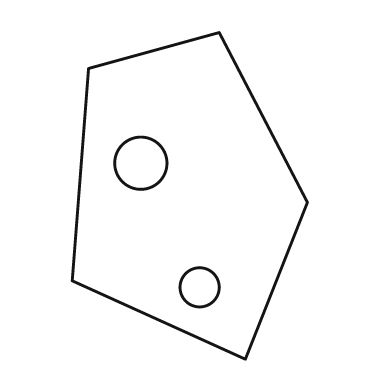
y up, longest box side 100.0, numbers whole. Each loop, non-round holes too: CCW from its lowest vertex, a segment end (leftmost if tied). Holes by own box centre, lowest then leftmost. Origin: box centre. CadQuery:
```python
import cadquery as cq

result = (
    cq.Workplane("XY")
    .moveTo(17.0, -50.0)
    .lineTo(36.0, -2.0)
    .lineTo(9.0, 50.0)
    .lineTo(-31.0, 39.0)
    .lineTo(-36.0, -26.0)
    .close()
    .moveTo(3.0, -28.0)
    .circle(6.0)
    .moveTo(-15.0, 10.0)
    .circle(8.0)
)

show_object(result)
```